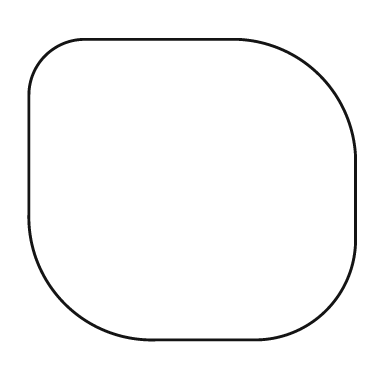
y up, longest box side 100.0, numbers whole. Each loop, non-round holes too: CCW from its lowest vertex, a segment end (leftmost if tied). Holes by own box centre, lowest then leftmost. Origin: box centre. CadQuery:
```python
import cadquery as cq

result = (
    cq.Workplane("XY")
    .moveTo(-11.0, -46.0)
    .lineTo(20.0, -46.0)
    .threePointArc((41.0, -37.0), (50.0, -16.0))
    .lineTo(50.0, 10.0)
    .threePointArc((39.0, 35.0), (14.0, 46.0))
    .lineTo(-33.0, 46.0)
    .threePointArc((-45.0, 41.0), (-50.0, 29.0))
    .lineTo(-50.0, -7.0)
    .threePointArc((-39.0, -35.0), (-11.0, -46.0))
    .close()
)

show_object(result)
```